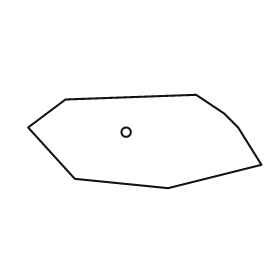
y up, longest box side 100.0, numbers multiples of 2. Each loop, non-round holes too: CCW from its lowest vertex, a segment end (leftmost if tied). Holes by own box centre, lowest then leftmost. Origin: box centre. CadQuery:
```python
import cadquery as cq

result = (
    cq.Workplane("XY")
    .moveTo(10.0, -20.0)
    .lineTo(50.0, -10.0)
    .lineTo(40.0, 6.0)
    .lineTo(34.0, 12.0)
    .lineTo(22.0, 20.0)
    .lineTo(-34.0, 18.0)
    .lineTo(-50.0, 6.0)
    .lineTo(-30.0, -16.0)
    .close()
    .moveTo(-8.0, 4.0)
    .circle(2.0)
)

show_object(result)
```